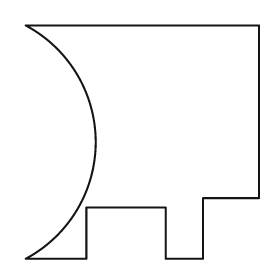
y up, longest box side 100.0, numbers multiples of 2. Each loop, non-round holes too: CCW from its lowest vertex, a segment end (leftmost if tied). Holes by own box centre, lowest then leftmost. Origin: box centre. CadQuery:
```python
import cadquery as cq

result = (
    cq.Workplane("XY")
    .moveTo(-50.0, -50.0)
    .lineTo(-24.0, -50.0)
    .lineTo(-24.0, -28.0)
    .lineTo(10.0, -28.0)
    .lineTo(10.0, -50.0)
    .lineTo(26.0, -50.0)
    .lineTo(26.0, -24.0)
    .lineTo(50.0, -24.0)
    .lineTo(50.0, 50.0)
    .lineTo(-50.0, 50.0)
    .threePointArc((-20.0, 0.0), (-50.0, -50.0))
    .close()
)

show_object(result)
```